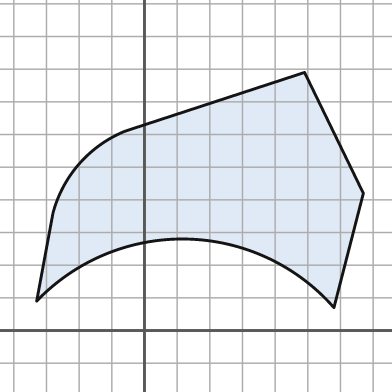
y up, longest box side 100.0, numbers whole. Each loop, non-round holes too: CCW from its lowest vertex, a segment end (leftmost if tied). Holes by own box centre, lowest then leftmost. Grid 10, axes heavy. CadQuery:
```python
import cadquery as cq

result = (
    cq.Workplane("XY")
    .moveTo(58.0, 7.0)
    .lineTo(67.0, 42.0)
    .lineTo(49.0, 79.0)
    .lineTo(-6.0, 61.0)
    .threePointArc((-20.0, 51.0), (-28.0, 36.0))
    .lineTo(-33.0, 9.0)
    .threePointArc((13.0, 28.0), (58.0, 7.0))
    .close()
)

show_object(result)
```